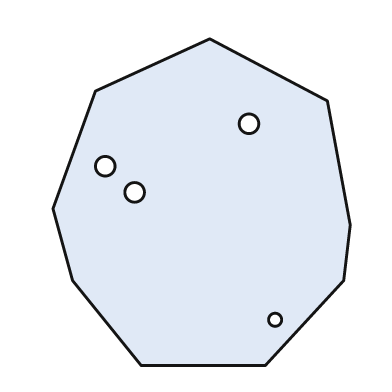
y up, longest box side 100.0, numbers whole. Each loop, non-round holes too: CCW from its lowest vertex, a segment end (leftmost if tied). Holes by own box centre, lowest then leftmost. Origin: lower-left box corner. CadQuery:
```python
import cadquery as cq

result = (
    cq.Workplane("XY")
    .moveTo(27.0, 0.0)
    .lineTo(65.0, 0.0)
    .lineTo(89.0, 26.0)
    .lineTo(91.0, 43.0)
    .lineTo(84.0, 81.0)
    .lineTo(48.0, 100.0)
    .lineTo(13.0, 84.0)
    .lineTo(0.0, 48.0)
    .lineTo(6.0, 26.0)
    .close()
    .moveTo(68.0, 14.0)
    .circle(2.0)
    .moveTo(25.0, 53.0)
    .circle(3.0)
    .moveTo(16.0, 61.0)
    .circle(3.0)
    .moveTo(60.0, 74.0)
    .circle(3.0)
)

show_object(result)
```